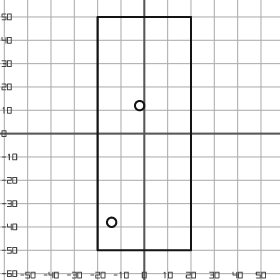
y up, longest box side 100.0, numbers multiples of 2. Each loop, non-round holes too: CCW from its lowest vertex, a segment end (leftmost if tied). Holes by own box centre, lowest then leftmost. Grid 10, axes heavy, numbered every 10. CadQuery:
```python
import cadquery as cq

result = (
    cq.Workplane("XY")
    .moveTo(-20.0, -50.0)
    .lineTo(20.0, -50.0)
    .lineTo(20.0, 50.0)
    .lineTo(-20.0, 50.0)
    .close()
    .moveTo(-14.0, -38.0)
    .circle(2.0)
    .moveTo(-2.0, 12.0)
    .circle(2.0)
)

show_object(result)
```